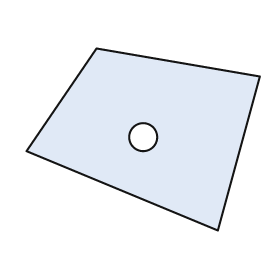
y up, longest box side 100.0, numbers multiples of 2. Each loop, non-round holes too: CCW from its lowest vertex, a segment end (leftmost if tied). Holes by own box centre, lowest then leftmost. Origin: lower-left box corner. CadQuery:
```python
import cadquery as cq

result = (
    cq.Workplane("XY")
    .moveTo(82.0, 0.0)
    .lineTo(100.0, 66.0)
    .lineTo(30.0, 78.0)
    .lineTo(0.0, 34.0)
    .close()
    .moveTo(50.0, 40.0)
    .circle(6.0)
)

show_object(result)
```